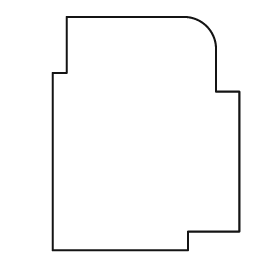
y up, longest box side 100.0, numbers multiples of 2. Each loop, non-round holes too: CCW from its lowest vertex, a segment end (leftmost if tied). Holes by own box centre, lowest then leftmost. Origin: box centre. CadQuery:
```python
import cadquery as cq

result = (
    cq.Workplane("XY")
    .moveTo(-40.0, -50.0)
    .lineTo(18.0, -50.0)
    .lineTo(18.0, -42.0)
    .lineTo(40.0, -42.0)
    .lineTo(40.0, 18.0)
    .lineTo(30.0, 18.0)
    .lineTo(30.0, 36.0)
    .threePointArc((26.0, 46.0), (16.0, 50.0))
    .lineTo(-34.0, 50.0)
    .lineTo(-34.0, 26.0)
    .lineTo(-40.0, 26.0)
    .close()
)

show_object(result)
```